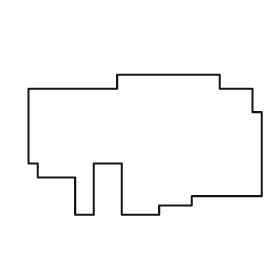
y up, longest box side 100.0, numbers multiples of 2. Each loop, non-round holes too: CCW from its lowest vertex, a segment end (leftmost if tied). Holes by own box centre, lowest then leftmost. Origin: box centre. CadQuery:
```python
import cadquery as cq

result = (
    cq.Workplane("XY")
    .moveTo(-30.0, -30.0)
    .lineTo(-22.0, -30.0)
    .lineTo(-22.0, -8.0)
    .lineTo(-10.0, -8.0)
    .lineTo(-10.0, -30.0)
    .lineTo(6.0, -30.0)
    .lineTo(6.0, -26.0)
    .lineTo(20.0, -26.0)
    .lineTo(20.0, -22.0)
    .lineTo(50.0, -22.0)
    .lineTo(50.0, 14.0)
    .lineTo(46.0, 14.0)
    .lineTo(46.0, 24.0)
    .lineTo(32.0, 24.0)
    .lineTo(32.0, 30.0)
    .lineTo(-12.0, 30.0)
    .lineTo(-12.0, 24.0)
    .lineTo(-50.0, 24.0)
    .lineTo(-50.0, -8.0)
    .lineTo(-46.0, -8.0)
    .lineTo(-46.0, -14.0)
    .lineTo(-30.0, -14.0)
    .close()
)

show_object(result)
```